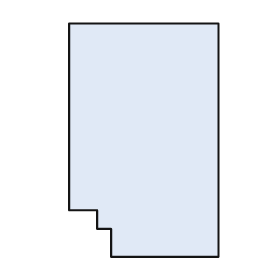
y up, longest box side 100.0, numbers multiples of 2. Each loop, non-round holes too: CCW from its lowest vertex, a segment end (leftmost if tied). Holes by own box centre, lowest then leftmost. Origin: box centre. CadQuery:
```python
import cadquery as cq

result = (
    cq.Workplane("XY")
    .moveTo(-14.0, -50.0)
    .lineTo(32.0, -50.0)
    .lineTo(32.0, 50.0)
    .lineTo(-32.0, 50.0)
    .lineTo(-32.0, -30.0)
    .lineTo(-20.0, -30.0)
    .lineTo(-20.0, -38.0)
    .lineTo(-14.0, -38.0)
    .close()
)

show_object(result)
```